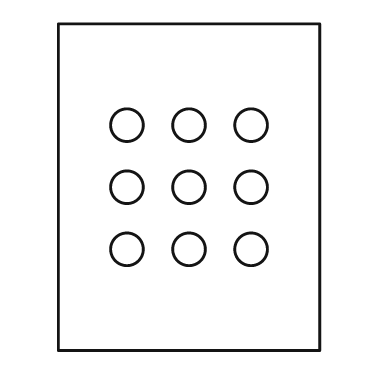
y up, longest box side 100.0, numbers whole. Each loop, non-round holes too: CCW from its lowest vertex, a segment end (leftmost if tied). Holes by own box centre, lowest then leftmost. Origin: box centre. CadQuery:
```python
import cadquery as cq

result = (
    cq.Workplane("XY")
    .moveTo(-40.0, -50.0)
    .lineTo(40.0, -50.0)
    .lineTo(40.0, 50.0)
    .lineTo(-40.0, 50.0)
    .close()
    .moveTo(-19.0, -19.0)
    .circle(5.0)
    .moveTo(0.0, -19.0)
    .circle(5.0)
    .moveTo(19.0, -19.0)
    .circle(5.0)
    .moveTo(-19.0, 0.0)
    .circle(5.0)
    .moveTo(0.0, 0.0)
    .circle(5.0)
    .moveTo(19.0, 0.0)
    .circle(5.0)
    .moveTo(-19.0, 19.0)
    .circle(5.0)
    .moveTo(0.0, 19.0)
    .circle(5.0)
    .moveTo(19.0, 19.0)
    .circle(5.0)
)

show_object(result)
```